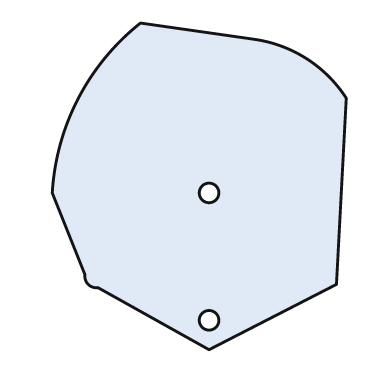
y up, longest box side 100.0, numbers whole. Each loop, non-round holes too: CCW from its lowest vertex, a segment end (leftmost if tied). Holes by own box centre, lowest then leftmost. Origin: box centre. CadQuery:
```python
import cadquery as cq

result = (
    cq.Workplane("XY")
    .moveTo(3.0, -50.0)
    .lineTo(42.0, -30.0)
    .lineTo(45.0, 27.0)
    .threePointArc((33.0, 39.0), (17.0, 45.0))
    .lineTo(-18.0, 50.0)
    .threePointArc((-37.0, 27.0), (-45.0, -2.0))
    .lineTo(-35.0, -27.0)
    .threePointArc((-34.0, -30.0), (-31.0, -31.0))
    .close()
    .moveTo(3.0, -41.0)
    .circle(3.0)
    .moveTo(3.0, -2.0)
    .circle(3.0)
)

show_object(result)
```